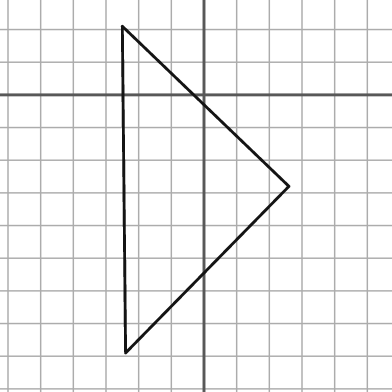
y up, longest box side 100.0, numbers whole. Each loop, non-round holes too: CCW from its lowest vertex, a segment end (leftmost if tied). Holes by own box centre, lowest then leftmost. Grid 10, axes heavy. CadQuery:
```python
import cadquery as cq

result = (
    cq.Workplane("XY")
    .moveTo(-24.0, -79.0)
    .lineTo(26.0, -28.0)
    .lineTo(-25.0, 21.0)
    .close()
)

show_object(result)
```